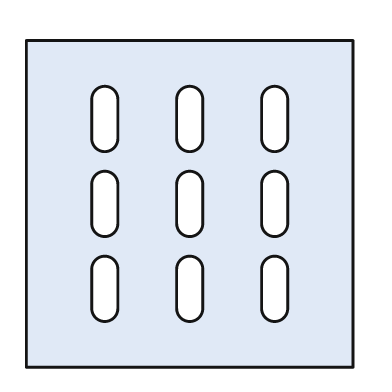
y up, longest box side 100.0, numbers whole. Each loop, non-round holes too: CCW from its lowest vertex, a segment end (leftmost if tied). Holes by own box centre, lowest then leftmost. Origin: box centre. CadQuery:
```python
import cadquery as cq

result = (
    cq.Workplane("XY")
    .moveTo(-50.0, -50.0)
    .lineTo(50.0, -50.0)
    .lineTo(50.0, 50.0)
    .lineTo(-50.0, 50.0)
    .close()
    .moveTo(-30.0, -32.0)
    .threePointArc((-26.0, -36.0), (-22.0, -32.0))
    .lineTo(-22.0, -20.0)
    .threePointArc((-26.0, -16.0), (-30.0, -20.0))
    .close()
    .moveTo(-4.0, -32.0)
    .threePointArc((0.0, -36.0), (4.0, -32.0))
    .lineTo(4.0, -20.0)
    .threePointArc((0.0, -16.0), (-4.0, -20.0))
    .close()
    .moveTo(22.0, -32.0)
    .threePointArc((26.0, -36.0), (30.0, -32.0))
    .lineTo(30.0, -20.0)
    .threePointArc((26.0, -16.0), (22.0, -20.0))
    .close()
    .moveTo(-30.0, -6.0)
    .threePointArc((-26.0, -10.0), (-22.0, -6.0))
    .lineTo(-22.0, 6.0)
    .threePointArc((-26.0, 10.0), (-30.0, 6.0))
    .close()
    .moveTo(-4.0, -6.0)
    .threePointArc((0.0, -10.0), (4.0, -6.0))
    .lineTo(4.0, 6.0)
    .threePointArc((0.0, 10.0), (-4.0, 6.0))
    .close()
    .moveTo(22.0, -6.0)
    .threePointArc((26.0, -10.0), (30.0, -6.0))
    .lineTo(30.0, 6.0)
    .threePointArc((26.0, 10.0), (22.0, 6.0))
    .close()
    .moveTo(-30.0, 20.0)
    .threePointArc((-26.0, 16.0), (-22.0, 20.0))
    .lineTo(-22.0, 32.0)
    .threePointArc((-26.0, 36.0), (-30.0, 32.0))
    .close()
    .moveTo(-4.0, 20.0)
    .threePointArc((0.0, 16.0), (4.0, 20.0))
    .lineTo(4.0, 32.0)
    .threePointArc((0.0, 36.0), (-4.0, 32.0))
    .close()
    .moveTo(22.0, 20.0)
    .threePointArc((26.0, 16.0), (30.0, 20.0))
    .lineTo(30.0, 32.0)
    .threePointArc((26.0, 36.0), (22.0, 32.0))
    .close()
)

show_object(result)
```